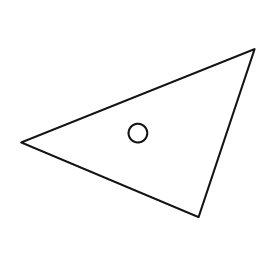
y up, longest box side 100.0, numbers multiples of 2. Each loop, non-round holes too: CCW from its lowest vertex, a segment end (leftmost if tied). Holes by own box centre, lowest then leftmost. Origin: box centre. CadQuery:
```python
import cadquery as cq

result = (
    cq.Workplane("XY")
    .moveTo(26.0, -36.0)
    .lineTo(50.0, 36.0)
    .lineTo(-50.0, -4.0)
    .close()
    .moveTo(0.0, 0.0)
    .circle(4.0)
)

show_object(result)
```